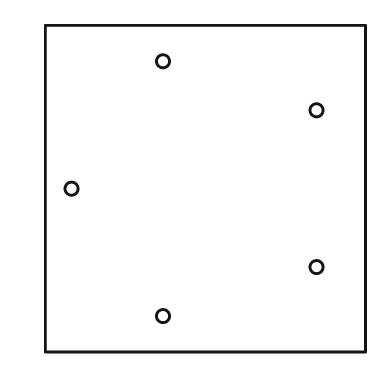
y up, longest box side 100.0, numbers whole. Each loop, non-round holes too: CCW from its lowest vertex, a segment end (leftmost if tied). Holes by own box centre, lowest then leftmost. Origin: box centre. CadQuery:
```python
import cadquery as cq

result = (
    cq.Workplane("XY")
    .moveTo(-49.0, -50.0)
    .lineTo(49.0, -50.0)
    .lineTo(49.0, 50.0)
    .lineTo(-49.0, 50.0)
    .close()
    .moveTo(-13.0, -39.0)
    .circle(2.0)
    .moveTo(34.0, -24.0)
    .circle(2.0)
    .moveTo(-41.0, 0.0)
    .circle(2.0)
    .moveTo(34.0, 24.0)
    .circle(2.0)
    .moveTo(-13.0, 39.0)
    .circle(2.0)
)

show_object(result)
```